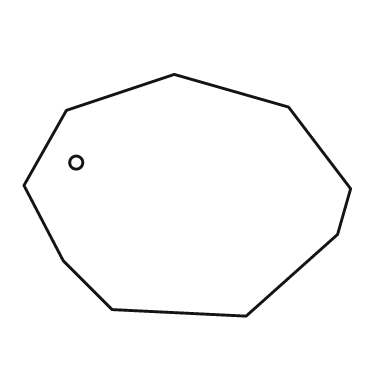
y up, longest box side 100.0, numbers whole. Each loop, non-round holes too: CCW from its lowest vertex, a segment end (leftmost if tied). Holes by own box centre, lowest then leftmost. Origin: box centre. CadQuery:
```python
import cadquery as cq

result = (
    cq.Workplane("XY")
    .moveTo(18.0, -37.0)
    .lineTo(46.0, -12.0)
    .lineTo(50.0, 2.0)
    .lineTo(31.0, 27.0)
    .lineTo(-4.0, 37.0)
    .lineTo(-37.0, 26.0)
    .lineTo(-50.0, 3.0)
    .lineTo(-38.0, -20.0)
    .lineTo(-23.0, -35.0)
    .close()
    .moveTo(-34.0, 10.0)
    .circle(2.0)
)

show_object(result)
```